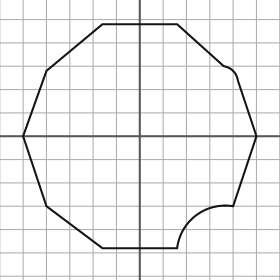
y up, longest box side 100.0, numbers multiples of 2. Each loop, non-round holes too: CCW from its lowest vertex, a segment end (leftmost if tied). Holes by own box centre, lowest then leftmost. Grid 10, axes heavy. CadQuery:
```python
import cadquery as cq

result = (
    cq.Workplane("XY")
    .moveTo(-16.0, -48.0)
    .lineTo(16.0, -48.0)
    .threePointArc((24.0, -34.0), (40.0, -30.0))
    .lineTo(50.0, 0.0)
    .lineTo(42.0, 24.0)
    .threePointArc((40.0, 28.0), (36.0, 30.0))
    .lineTo(16.0, 48.0)
    .lineTo(-16.0, 48.0)
    .lineTo(-40.0, 28.0)
    .lineTo(-50.0, 0.0)
    .lineTo(-40.0, -30.0)
    .close()
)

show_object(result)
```